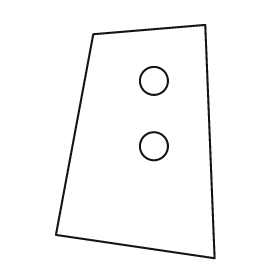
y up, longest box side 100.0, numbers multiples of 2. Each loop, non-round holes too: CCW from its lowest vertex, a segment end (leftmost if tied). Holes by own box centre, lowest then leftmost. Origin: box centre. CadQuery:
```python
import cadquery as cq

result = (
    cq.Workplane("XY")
    .moveTo(34.0, -50.0)
    .lineTo(30.0, 50.0)
    .lineTo(-18.0, 46.0)
    .lineTo(-34.0, -40.0)
    .close()
    .moveTo(8.0, -2.0)
    .circle(6.0)
    .moveTo(8.0, 26.0)
    .circle(6.0)
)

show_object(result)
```